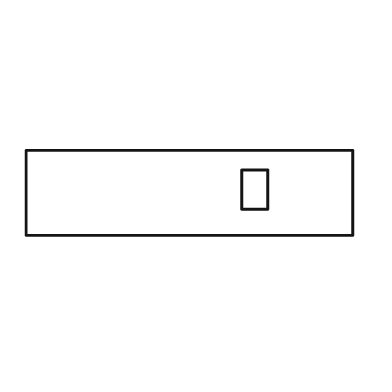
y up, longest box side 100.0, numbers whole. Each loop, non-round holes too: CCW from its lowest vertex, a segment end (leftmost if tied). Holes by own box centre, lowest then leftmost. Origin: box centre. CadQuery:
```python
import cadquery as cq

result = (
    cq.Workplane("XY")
    .moveTo(-50.0, -13.0)
    .lineTo(50.0, -13.0)
    .lineTo(50.0, 13.0)
    .lineTo(-50.0, 13.0)
    .close()
    .moveTo(16.0, -5.0)
    .lineTo(24.0, -5.0)
    .lineTo(24.0, 7.0)
    .lineTo(16.0, 7.0)
    .close()
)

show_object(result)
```